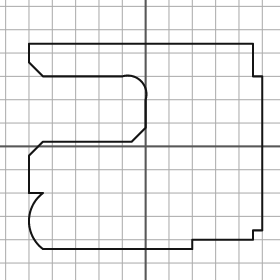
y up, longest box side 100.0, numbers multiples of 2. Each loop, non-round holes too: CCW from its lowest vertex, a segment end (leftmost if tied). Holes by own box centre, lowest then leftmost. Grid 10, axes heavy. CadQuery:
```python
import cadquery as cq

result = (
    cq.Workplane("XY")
    .moveTo(-44.0, -44.0)
    .lineTo(20.0, -44.0)
    .lineTo(20.0, -40.0)
    .lineTo(46.0, -40.0)
    .lineTo(46.0, -36.0)
    .lineTo(50.0, -36.0)
    .lineTo(50.0, 30.0)
    .lineTo(46.0, 30.0)
    .lineTo(46.0, 44.0)
    .lineTo(-50.0, 44.0)
    .lineTo(-50.0, 36.0)
    .lineTo(-44.0, 30.0)
    .lineTo(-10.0, 30.0)
    .threePointArc((-2.0, 28.0), (0.0, 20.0))
    .lineTo(0.0, 8.0)
    .lineTo(-6.0, 2.0)
    .lineTo(-44.0, 2.0)
    .lineTo(-50.0, -4.0)
    .lineTo(-50.0, -20.0)
    .lineTo(-44.0, -20.0)
    .threePointArc((-50.0, -32.0), (-44.0, -44.0))
    .close()
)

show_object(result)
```